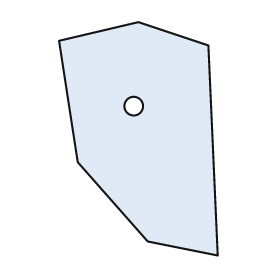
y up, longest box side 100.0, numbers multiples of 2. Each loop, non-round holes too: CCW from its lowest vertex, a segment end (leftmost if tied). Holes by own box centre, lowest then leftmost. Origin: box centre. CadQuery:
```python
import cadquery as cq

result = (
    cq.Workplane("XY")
    .moveTo(34.0, -50.0)
    .lineTo(30.0, 40.0)
    .lineTo(0.0, 50.0)
    .lineTo(-34.0, 42.0)
    .lineTo(-26.0, -10.0)
    .lineTo(4.0, -44.0)
    .close()
    .moveTo(-2.0, 14.0)
    .circle(4.0)
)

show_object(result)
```